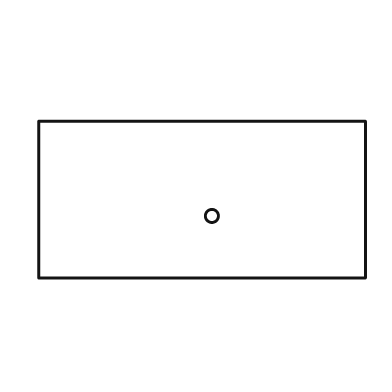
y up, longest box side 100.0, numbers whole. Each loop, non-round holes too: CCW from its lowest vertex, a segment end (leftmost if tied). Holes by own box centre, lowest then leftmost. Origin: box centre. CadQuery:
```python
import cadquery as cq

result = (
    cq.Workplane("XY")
    .moveTo(-50.0, -24.0)
    .lineTo(50.0, -24.0)
    .lineTo(50.0, 24.0)
    .lineTo(-50.0, 24.0)
    .close()
    .moveTo(3.0, -5.0)
    .circle(2.0)
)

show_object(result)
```